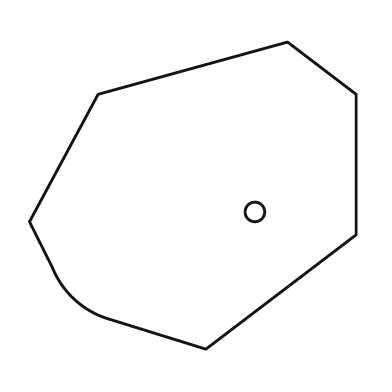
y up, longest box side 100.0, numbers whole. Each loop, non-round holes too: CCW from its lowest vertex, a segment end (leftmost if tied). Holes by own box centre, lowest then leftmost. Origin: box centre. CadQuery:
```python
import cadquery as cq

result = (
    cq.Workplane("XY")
    .moveTo(4.0, -47.0)
    .lineTo(50.0, -12.0)
    .lineTo(50.0, 31.0)
    .lineTo(29.0, 47.0)
    .lineTo(-29.0, 31.0)
    .lineTo(-50.0, -8.0)
    .lineTo(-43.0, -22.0)
    .threePointArc((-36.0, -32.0), (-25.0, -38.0))
    .close()
    .moveTo(19.0, -5.0)
    .circle(3.0)
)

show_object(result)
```